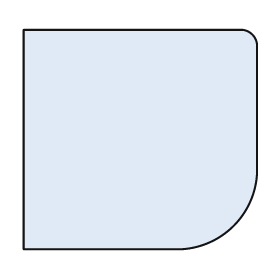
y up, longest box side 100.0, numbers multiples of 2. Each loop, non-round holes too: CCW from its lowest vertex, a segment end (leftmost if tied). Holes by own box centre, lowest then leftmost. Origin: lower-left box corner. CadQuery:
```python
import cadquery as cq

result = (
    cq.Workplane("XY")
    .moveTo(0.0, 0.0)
    .lineTo(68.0, 0.0)
    .threePointArc((90.0, 10.0), (100.0, 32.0))
    .lineTo(100.0, 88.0)
    .threePointArc((98.0, 92.0), (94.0, 94.0))
    .lineTo(0.0, 94.0)
    .close()
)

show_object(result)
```